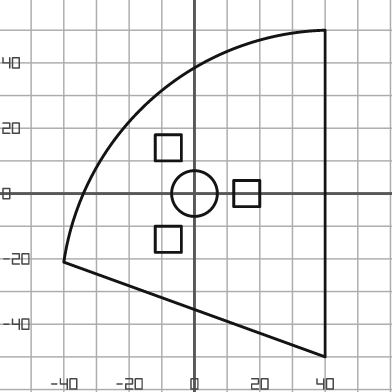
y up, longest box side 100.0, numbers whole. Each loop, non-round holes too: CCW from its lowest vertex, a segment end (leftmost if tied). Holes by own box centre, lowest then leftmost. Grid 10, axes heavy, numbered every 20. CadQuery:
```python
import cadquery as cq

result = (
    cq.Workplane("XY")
    .moveTo(40.0, -50.0)
    .lineTo(40.0, 50.0)
    .threePointArc((-13.0, 29.0), (-40.0, -21.0))
    .close()
    .moveTo(-12.0, -18.0)
    .lineTo(-4.0, -18.0)
    .lineTo(-4.0, -10.0)
    .lineTo(-12.0, -10.0)
    .close()
    .moveTo(0.0, 0.0)
    .circle(7.0)
    .moveTo(12.0, -4.0)
    .lineTo(20.0, -4.0)
    .lineTo(20.0, 4.0)
    .lineTo(12.0, 4.0)
    .close()
    .moveTo(-12.0, 10.0)
    .lineTo(-4.0, 10.0)
    .lineTo(-4.0, 18.0)
    .lineTo(-12.0, 18.0)
    .close()
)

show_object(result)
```